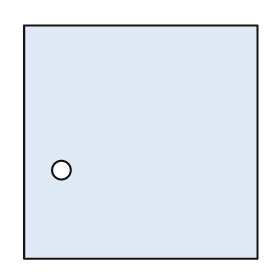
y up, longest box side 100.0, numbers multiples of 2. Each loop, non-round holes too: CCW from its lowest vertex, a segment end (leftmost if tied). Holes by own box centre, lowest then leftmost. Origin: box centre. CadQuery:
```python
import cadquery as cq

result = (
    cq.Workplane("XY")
    .moveTo(-50.0, -50.0)
    .lineTo(50.0, -50.0)
    .lineTo(50.0, 50.0)
    .lineTo(-50.0, 50.0)
    .close()
    .moveTo(-34.0, -12.0)
    .circle(4.0)
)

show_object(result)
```